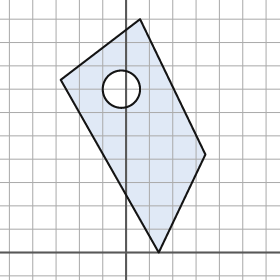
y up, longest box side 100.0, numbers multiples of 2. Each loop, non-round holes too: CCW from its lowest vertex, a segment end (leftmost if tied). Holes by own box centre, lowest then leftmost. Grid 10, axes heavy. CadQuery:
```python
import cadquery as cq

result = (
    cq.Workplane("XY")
    .moveTo(14.0, 0.0)
    .lineTo(34.0, 42.0)
    .lineTo(6.0, 100.0)
    .lineTo(-28.0, 74.0)
    .close()
    .moveTo(-2.0, 70.0)
    .circle(8.0)
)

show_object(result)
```